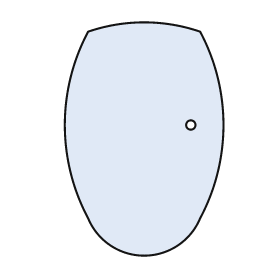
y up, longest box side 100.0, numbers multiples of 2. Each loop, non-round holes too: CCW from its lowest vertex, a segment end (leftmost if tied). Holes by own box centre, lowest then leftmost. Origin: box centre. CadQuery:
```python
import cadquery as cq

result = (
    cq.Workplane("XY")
    .moveTo(-24.0, -34.0)
    .threePointArc((0.0, -50.0), (24.0, -34.0))
    .threePointArc((34.0, 6.0), (24.0, 46.0))
    .threePointArc((0.0, 50.0), (-24.0, 46.0))
    .threePointArc((-34.0, 6.0), (-24.0, -34.0))
    .close()
    .moveTo(20.0, 6.0)
    .circle(2.0)
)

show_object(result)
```